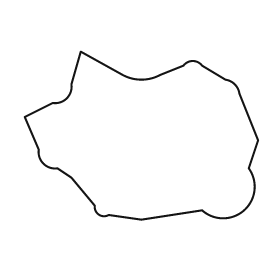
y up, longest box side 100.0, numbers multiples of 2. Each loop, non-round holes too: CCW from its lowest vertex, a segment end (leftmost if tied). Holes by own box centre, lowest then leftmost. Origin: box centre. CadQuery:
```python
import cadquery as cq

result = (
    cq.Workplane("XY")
    .moveTo(0.0, -36.0)
    .lineTo(26.0, -32.0)
    .threePointArc((44.0, -32.0), (46.0, -14.0))
    .lineTo(50.0, -2.0)
    .lineTo(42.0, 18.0)
    .threePointArc((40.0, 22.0), (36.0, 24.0))
    .lineTo(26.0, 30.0)
    .threePointArc((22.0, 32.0), (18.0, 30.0))
    .lineTo(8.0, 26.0)
    .threePointArc((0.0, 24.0), (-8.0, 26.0))
    .lineTo(-26.0, 36.0)
    .lineTo(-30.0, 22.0)
    .threePointArc((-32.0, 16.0), (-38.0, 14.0))
    .lineTo(-50.0, 8.0)
    .lineTo(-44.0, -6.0)
    .threePointArc((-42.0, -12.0), (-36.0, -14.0))
    .lineTo(-30.0, -18.0)
    .lineTo(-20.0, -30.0)
    .threePointArc((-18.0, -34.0), (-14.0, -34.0))
    .close()
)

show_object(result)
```